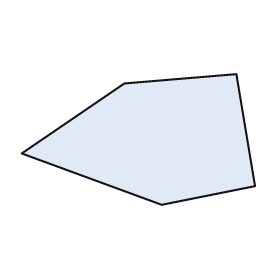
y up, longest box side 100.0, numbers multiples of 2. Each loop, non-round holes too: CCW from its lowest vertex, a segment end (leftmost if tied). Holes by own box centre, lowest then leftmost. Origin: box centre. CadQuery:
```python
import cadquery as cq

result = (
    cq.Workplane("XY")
    .moveTo(10.0, -28.0)
    .lineTo(50.0, -20.0)
    .lineTo(42.0, 28.0)
    .lineTo(-6.0, 24.0)
    .lineTo(-50.0, -6.0)
    .close()
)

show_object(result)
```